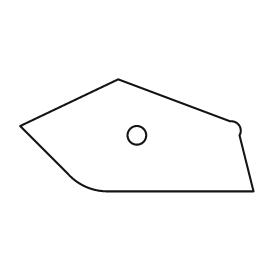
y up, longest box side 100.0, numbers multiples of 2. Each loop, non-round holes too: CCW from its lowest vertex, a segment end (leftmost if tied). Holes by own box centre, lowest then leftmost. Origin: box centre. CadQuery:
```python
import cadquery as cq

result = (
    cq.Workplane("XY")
    .moveTo(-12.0, -24.0)
    .lineTo(50.0, -24.0)
    .lineTo(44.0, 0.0)
    .threePointArc((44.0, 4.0), (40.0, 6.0))
    .lineTo(-8.0, 24.0)
    .lineTo(-50.0, 4.0)
    .lineTo(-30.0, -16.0)
    .threePointArc((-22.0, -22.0), (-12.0, -24.0))
    .close()
    .moveTo(0.0, 0.0)
    .circle(4.0)
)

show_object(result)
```